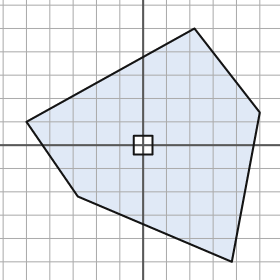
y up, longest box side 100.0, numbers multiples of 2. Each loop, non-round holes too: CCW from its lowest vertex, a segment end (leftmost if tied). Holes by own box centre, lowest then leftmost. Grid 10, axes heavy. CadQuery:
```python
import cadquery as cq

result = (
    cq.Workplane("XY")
    .moveTo(38.0, -50.0)
    .lineTo(50.0, 14.0)
    .lineTo(22.0, 50.0)
    .lineTo(-50.0, 10.0)
    .lineTo(-28.0, -22.0)
    .close()
    .moveTo(-4.0, -4.0)
    .lineTo(4.0, -4.0)
    .lineTo(4.0, 4.0)
    .lineTo(-4.0, 4.0)
    .close()
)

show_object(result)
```